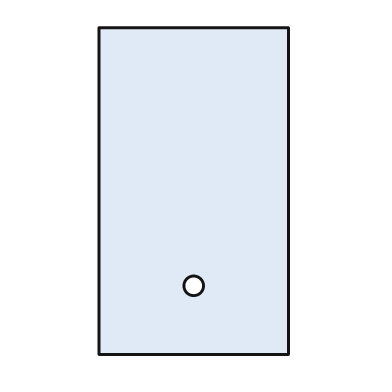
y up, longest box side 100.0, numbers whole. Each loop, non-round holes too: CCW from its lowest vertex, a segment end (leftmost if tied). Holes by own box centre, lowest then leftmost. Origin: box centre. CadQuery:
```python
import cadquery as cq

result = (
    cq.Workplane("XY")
    .moveTo(-29.0, -50.0)
    .lineTo(29.0, -50.0)
    .lineTo(29.0, 50.0)
    .lineTo(-29.0, 50.0)
    .close()
    .moveTo(0.0, -29.0)
    .circle(3.0)
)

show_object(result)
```